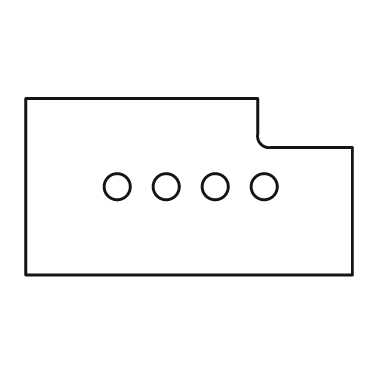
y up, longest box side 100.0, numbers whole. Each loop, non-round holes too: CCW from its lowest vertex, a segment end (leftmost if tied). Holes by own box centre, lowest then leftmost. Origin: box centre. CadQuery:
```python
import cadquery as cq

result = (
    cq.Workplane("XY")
    .moveTo(-50.0, -27.0)
    .lineTo(50.0, -27.0)
    .lineTo(50.0, 12.0)
    .lineTo(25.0, 12.0)
    .threePointArc((22.0, 13.0), (21.0, 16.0))
    .lineTo(21.0, 27.0)
    .lineTo(-50.0, 27.0)
    .close()
    .moveTo(-22.0, 0.0)
    .circle(4.0)
    .moveTo(-7.0, 0.0)
    .circle(4.0)
    .moveTo(8.0, 0.0)
    .circle(4.0)
    .moveTo(23.0, 0.0)
    .circle(4.0)
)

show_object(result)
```